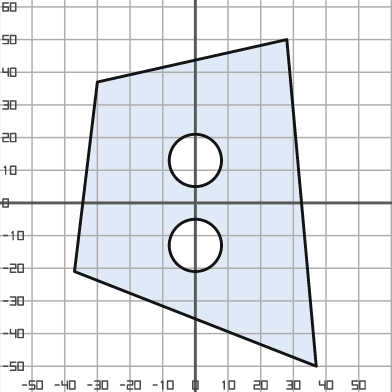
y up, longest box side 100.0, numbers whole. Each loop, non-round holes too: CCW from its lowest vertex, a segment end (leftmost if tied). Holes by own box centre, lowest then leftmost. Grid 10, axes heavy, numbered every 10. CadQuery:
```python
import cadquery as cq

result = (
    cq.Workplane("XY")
    .moveTo(37.0, -50.0)
    .lineTo(28.0, 50.0)
    .lineTo(-30.0, 37.0)
    .lineTo(-37.0, -21.0)
    .close()
    .moveTo(0.0, -13.0)
    .circle(8.0)
    .moveTo(0.0, 13.0)
    .circle(8.0)
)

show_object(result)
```